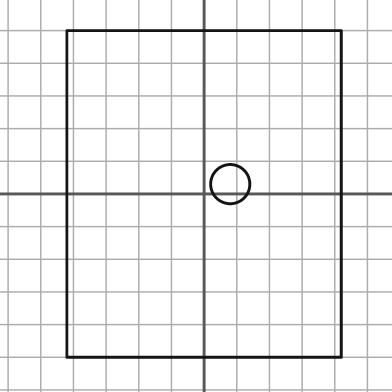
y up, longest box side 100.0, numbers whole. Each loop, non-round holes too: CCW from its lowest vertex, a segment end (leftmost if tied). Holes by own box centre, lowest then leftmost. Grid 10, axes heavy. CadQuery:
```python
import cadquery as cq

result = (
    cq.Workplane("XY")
    .moveTo(-42.0, -50.0)
    .lineTo(42.0, -50.0)
    .lineTo(42.0, 50.0)
    .lineTo(-42.0, 50.0)
    .close()
    .moveTo(8.0, 3.0)
    .circle(6.0)
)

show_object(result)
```